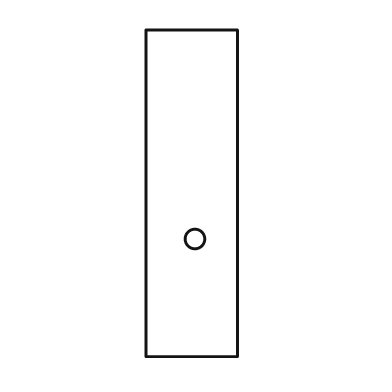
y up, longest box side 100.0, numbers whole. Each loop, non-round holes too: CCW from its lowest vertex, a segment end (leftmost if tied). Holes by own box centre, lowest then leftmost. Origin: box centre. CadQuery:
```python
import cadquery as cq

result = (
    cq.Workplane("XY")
    .moveTo(-14.0, -50.0)
    .lineTo(14.0, -50.0)
    .lineTo(14.0, 50.0)
    .lineTo(-14.0, 50.0)
    .close()
    .moveTo(1.0, -14.0)
    .circle(3.0)
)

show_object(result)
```